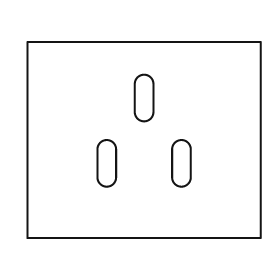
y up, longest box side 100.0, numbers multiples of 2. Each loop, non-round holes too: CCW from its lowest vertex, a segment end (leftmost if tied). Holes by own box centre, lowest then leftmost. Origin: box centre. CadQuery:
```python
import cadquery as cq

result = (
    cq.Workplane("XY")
    .moveTo(-50.0, -42.0)
    .lineTo(50.0, -42.0)
    .lineTo(50.0, 42.0)
    .lineTo(-50.0, 42.0)
    .close()
    .moveTo(-20.0, -16.0)
    .threePointArc((-16.0, -20.0), (-12.0, -16.0))
    .lineTo(-12.0, -4.0)
    .threePointArc((-16.0, 0.0), (-20.0, -4.0))
    .close()
    .moveTo(12.0, -16.0)
    .threePointArc((16.0, -20.0), (20.0, -16.0))
    .lineTo(20.0, -4.0)
    .threePointArc((16.0, 0.0), (12.0, -4.0))
    .close()
    .moveTo(-4.0, 12.0)
    .threePointArc((0.0, 8.0), (4.0, 12.0))
    .lineTo(4.0, 24.0)
    .threePointArc((0.0, 28.0), (-4.0, 24.0))
    .close()
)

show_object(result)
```